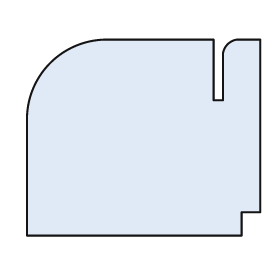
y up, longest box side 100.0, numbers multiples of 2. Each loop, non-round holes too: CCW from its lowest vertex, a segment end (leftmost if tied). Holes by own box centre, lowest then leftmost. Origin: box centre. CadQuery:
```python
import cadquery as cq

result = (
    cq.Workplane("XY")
    .moveTo(-50.0, -42.0)
    .lineTo(42.0, -42.0)
    .lineTo(42.0, -32.0)
    .lineTo(50.0, -32.0)
    .lineTo(50.0, 42.0)
    .lineTo(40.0, 42.0)
    .threePointArc((36.0, 40.0), (34.0, 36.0))
    .lineTo(34.0, 16.0)
    .lineTo(30.0, 16.0)
    .lineTo(30.0, 42.0)
    .lineTo(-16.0, 42.0)
    .threePointArc((-40.0, 32.0), (-50.0, 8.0))
    .close()
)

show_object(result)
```